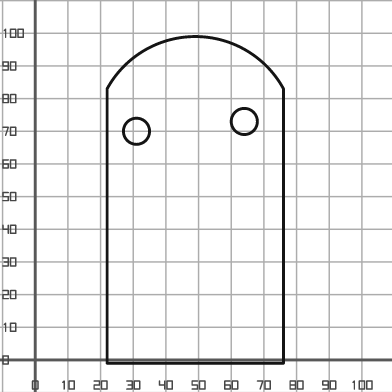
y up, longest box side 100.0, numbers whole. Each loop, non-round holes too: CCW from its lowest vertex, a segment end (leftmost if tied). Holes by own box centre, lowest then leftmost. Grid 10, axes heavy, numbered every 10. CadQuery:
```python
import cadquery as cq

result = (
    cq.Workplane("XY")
    .moveTo(22.0, -1.0)
    .lineTo(76.0, -1.0)
    .lineTo(76.0, 83.0)
    .threePointArc((49.0, 99.0), (22.0, 83.0))
    .close()
    .moveTo(31.0, 70.0)
    .circle(4.0)
    .moveTo(64.0, 73.0)
    .circle(4.0)
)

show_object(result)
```